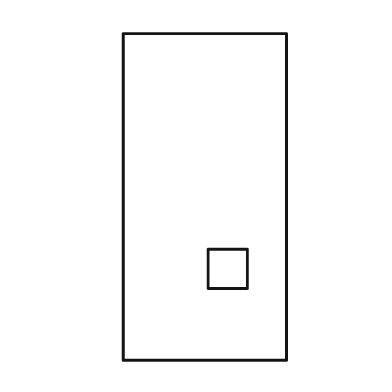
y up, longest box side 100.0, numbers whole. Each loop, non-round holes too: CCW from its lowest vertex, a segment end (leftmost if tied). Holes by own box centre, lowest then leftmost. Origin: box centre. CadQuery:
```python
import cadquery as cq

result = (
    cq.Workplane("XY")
    .moveTo(-25.0, -50.0)
    .lineTo(25.0, -50.0)
    .lineTo(25.0, 50.0)
    .lineTo(-25.0, 50.0)
    .close()
    .moveTo(1.0, -28.0)
    .lineTo(13.0, -28.0)
    .lineTo(13.0, -16.0)
    .lineTo(1.0, -16.0)
    .close()
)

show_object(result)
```